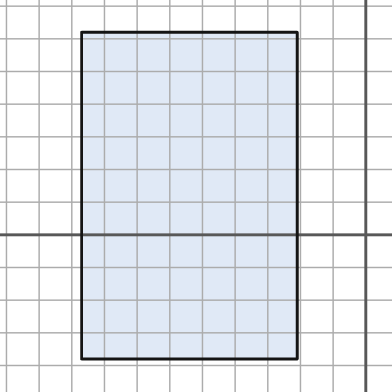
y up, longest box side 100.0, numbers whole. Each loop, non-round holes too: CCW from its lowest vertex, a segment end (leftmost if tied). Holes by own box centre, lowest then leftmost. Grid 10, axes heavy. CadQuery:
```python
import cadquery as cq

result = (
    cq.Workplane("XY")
    .moveTo(-87.0, -38.0)
    .lineTo(-21.0, -38.0)
    .lineTo(-21.0, 62.0)
    .lineTo(-87.0, 62.0)
    .close()
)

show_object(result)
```